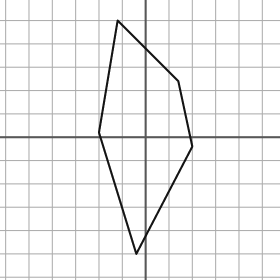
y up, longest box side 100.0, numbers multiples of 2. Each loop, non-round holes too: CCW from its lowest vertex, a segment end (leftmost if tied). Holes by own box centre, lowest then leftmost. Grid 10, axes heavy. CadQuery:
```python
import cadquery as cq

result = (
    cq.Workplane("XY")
    .moveTo(-4.0, -50.0)
    .lineTo(20.0, -4.0)
    .lineTo(14.0, 24.0)
    .lineTo(-12.0, 50.0)
    .lineTo(-20.0, 2.0)
    .close()
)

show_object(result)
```